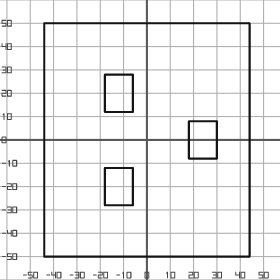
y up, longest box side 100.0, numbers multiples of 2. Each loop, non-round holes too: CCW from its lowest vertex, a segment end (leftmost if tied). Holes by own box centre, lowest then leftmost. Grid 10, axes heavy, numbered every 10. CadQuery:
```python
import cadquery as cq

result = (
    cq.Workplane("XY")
    .moveTo(-44.0, -50.0)
    .lineTo(44.0, -50.0)
    .lineTo(44.0, 50.0)
    .lineTo(-44.0, 50.0)
    .close()
    .moveTo(-18.0, -28.0)
    .lineTo(-6.0, -28.0)
    .lineTo(-6.0, -12.0)
    .lineTo(-18.0, -12.0)
    .close()
    .moveTo(18.0, -8.0)
    .lineTo(30.0, -8.0)
    .lineTo(30.0, 8.0)
    .lineTo(18.0, 8.0)
    .close()
    .moveTo(-18.0, 12.0)
    .lineTo(-6.0, 12.0)
    .lineTo(-6.0, 28.0)
    .lineTo(-18.0, 28.0)
    .close()
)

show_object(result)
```